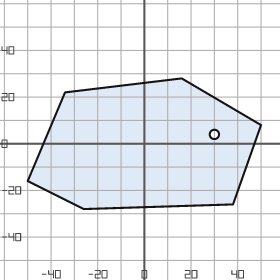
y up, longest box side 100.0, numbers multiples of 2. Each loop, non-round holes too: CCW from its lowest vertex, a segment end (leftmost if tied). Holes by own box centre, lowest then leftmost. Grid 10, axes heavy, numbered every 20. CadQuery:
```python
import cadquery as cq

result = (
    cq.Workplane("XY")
    .moveTo(-26.0, -28.0)
    .lineTo(38.0, -26.0)
    .lineTo(50.0, 8.0)
    .lineTo(16.0, 28.0)
    .lineTo(-34.0, 22.0)
    .lineTo(-50.0, -16.0)
    .close()
    .moveTo(30.0, 4.0)
    .circle(2.0)
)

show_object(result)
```